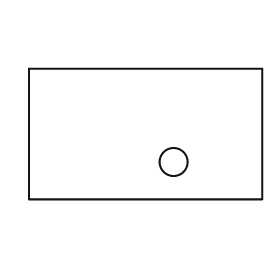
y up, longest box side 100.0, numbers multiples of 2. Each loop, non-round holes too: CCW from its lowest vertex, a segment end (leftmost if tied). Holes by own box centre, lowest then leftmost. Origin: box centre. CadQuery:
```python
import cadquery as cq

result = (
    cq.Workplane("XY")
    .moveTo(-50.0, -28.0)
    .lineTo(50.0, -28.0)
    .lineTo(50.0, 28.0)
    .lineTo(-50.0, 28.0)
    .close()
    .moveTo(12.0, -12.0)
    .circle(6.0)
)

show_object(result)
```